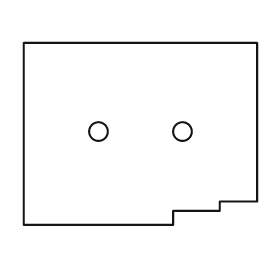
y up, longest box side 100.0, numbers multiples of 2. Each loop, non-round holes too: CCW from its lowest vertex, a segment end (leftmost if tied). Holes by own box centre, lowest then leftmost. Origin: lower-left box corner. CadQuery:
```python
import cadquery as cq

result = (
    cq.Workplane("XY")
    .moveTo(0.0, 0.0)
    .lineTo(64.0, 0.0)
    .lineTo(64.0, 6.0)
    .lineTo(84.0, 6.0)
    .lineTo(84.0, 10.0)
    .lineTo(100.0, 10.0)
    .lineTo(100.0, 78.0)
    .lineTo(0.0, 78.0)
    .close()
    .moveTo(32.0, 40.0)
    .circle(4.0)
    .moveTo(68.0, 40.0)
    .circle(4.0)
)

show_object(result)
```